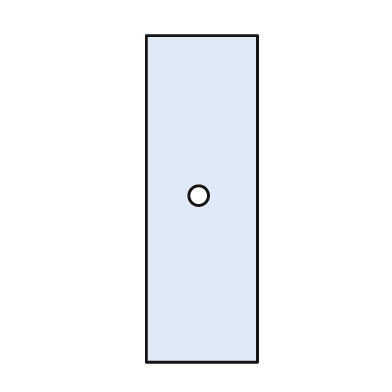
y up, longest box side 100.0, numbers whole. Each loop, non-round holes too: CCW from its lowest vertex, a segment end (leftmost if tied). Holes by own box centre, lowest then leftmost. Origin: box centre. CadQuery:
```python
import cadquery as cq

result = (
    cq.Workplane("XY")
    .moveTo(-17.0, -50.0)
    .lineTo(17.0, -50.0)
    .lineTo(17.0, 50.0)
    .lineTo(-17.0, 50.0)
    .close()
    .moveTo(-1.0, 1.0)
    .circle(3.0)
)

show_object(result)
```